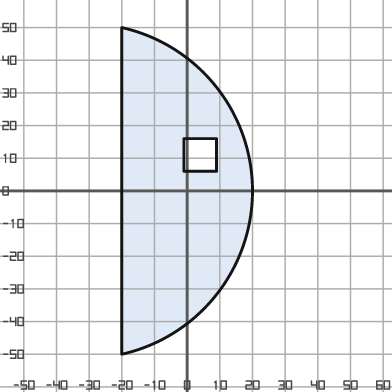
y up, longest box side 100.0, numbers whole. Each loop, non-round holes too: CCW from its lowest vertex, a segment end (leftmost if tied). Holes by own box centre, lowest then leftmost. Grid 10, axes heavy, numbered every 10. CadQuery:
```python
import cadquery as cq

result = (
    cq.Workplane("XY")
    .moveTo(-20.0, -50.0)
    .threePointArc((20.0, 0.0), (-20.0, 50.0))
    .close()
    .moveTo(-1.0, 6.0)
    .lineTo(9.0, 6.0)
    .lineTo(9.0, 16.0)
    .lineTo(-1.0, 16.0)
    .close()
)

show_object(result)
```